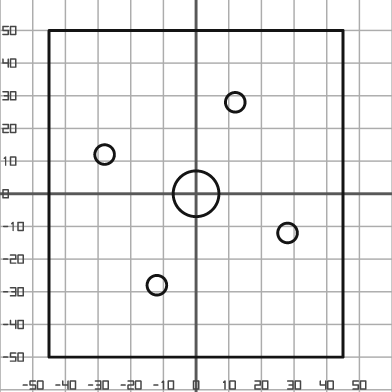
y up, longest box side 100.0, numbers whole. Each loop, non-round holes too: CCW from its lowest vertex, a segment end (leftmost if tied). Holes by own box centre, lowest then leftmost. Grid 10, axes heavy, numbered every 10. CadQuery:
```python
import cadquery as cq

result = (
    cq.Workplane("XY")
    .moveTo(-45.0, -50.0)
    .lineTo(45.0, -50.0)
    .lineTo(45.0, 50.0)
    .lineTo(-45.0, 50.0)
    .close()
    .moveTo(-12.0, -28.0)
    .circle(3.0)
    .moveTo(28.0, -12.0)
    .circle(3.0)
    .moveTo(0.0, 0.0)
    .circle(7.0)
    .moveTo(-28.0, 12.0)
    .circle(3.0)
    .moveTo(12.0, 28.0)
    .circle(3.0)
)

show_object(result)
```